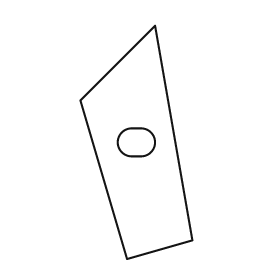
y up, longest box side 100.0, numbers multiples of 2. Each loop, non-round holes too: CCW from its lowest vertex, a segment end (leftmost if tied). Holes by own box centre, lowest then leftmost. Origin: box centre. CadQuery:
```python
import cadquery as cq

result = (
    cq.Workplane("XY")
    .moveTo(-4.0, -50.0)
    .lineTo(24.0, -42.0)
    .lineTo(8.0, 50.0)
    .lineTo(-24.0, 18.0)
    .close()
    .moveTo(-2.0, -6.0)
    .lineTo(2.0, -6.0)
    .threePointArc((8.0, 0.0), (2.0, 6.0))
    .lineTo(-2.0, 6.0)
    .threePointArc((-8.0, 0.0), (-2.0, -6.0))
    .close()
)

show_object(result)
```